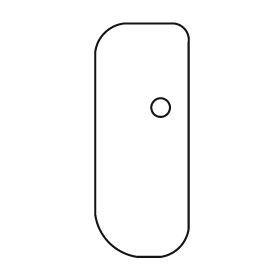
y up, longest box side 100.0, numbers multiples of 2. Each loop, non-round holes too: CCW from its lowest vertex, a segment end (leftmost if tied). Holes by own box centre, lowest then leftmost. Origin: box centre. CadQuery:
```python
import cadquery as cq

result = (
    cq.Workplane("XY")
    .moveTo(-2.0, -50.0)
    .lineTo(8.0, -50.0)
    .threePointArc((16.0, -46.0), (20.0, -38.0))
    .lineTo(20.0, 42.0)
    .threePointArc((18.0, 48.0), (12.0, 50.0))
    .lineTo(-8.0, 50.0)
    .threePointArc((-16.0, 46.0), (-20.0, 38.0))
    .lineTo(-20.0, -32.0)
    .threePointArc((-14.0, -44.0), (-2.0, -50.0))
    .close()
    .moveTo(8.0, 14.0)
    .circle(4.0)
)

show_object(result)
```